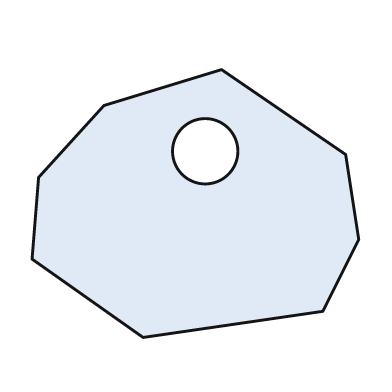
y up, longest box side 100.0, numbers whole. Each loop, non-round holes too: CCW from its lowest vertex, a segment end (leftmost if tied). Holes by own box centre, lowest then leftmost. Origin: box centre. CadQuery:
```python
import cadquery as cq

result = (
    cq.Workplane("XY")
    .moveTo(-16.0, -41.0)
    .lineTo(39.0, -33.0)
    .lineTo(50.0, -11.0)
    .lineTo(46.0, 15.0)
    .lineTo(8.0, 41.0)
    .lineTo(-28.0, 30.0)
    .lineTo(-48.0, 8.0)
    .lineTo(-50.0, -17.0)
    .close()
    .moveTo(3.0, 16.0)
    .circle(10.0)
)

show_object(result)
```